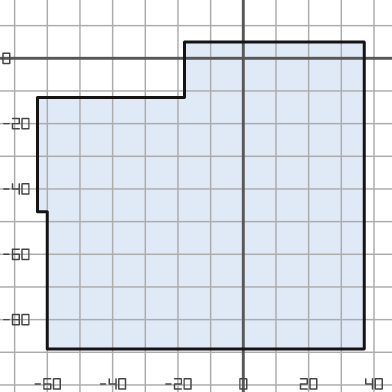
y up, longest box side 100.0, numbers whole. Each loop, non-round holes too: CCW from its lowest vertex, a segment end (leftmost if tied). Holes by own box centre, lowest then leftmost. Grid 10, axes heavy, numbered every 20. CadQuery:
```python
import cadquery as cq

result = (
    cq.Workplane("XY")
    .moveTo(-60.0, -89.0)
    .lineTo(37.0, -89.0)
    .lineTo(37.0, 5.0)
    .lineTo(-18.0, 5.0)
    .lineTo(-18.0, -12.0)
    .lineTo(-63.0, -12.0)
    .lineTo(-63.0, -47.0)
    .lineTo(-60.0, -47.0)
    .close()
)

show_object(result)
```